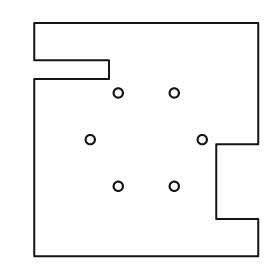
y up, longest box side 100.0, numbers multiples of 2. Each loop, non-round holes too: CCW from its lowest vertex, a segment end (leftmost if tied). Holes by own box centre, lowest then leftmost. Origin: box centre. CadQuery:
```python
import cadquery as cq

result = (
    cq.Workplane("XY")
    .moveTo(-48.0, -50.0)
    .lineTo(48.0, -50.0)
    .lineTo(48.0, -34.0)
    .lineTo(30.0, -34.0)
    .lineTo(30.0, -2.0)
    .lineTo(48.0, -2.0)
    .lineTo(48.0, 50.0)
    .lineTo(-48.0, 50.0)
    .lineTo(-48.0, 34.0)
    .lineTo(-16.0, 34.0)
    .lineTo(-16.0, 26.0)
    .lineTo(-48.0, 26.0)
    .close()
    .moveTo(-12.0, -20.0)
    .circle(2.0)
    .moveTo(12.0, -20.0)
    .circle(2.0)
    .moveTo(-24.0, 0.0)
    .circle(2.0)
    .moveTo(24.0, 0.0)
    .circle(2.0)
    .moveTo(-12.0, 20.0)
    .circle(2.0)
    .moveTo(12.0, 20.0)
    .circle(2.0)
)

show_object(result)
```